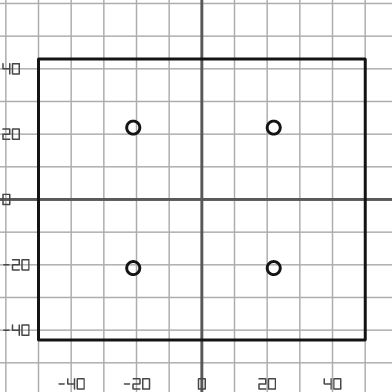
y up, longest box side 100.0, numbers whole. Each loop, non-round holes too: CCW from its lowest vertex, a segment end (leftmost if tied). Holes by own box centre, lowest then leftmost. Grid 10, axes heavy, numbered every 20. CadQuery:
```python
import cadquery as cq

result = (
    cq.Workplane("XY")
    .moveTo(-50.0, -43.0)
    .lineTo(50.0, -43.0)
    .lineTo(50.0, 43.0)
    .lineTo(-50.0, 43.0)
    .close()
    .moveTo(-21.0, -21.0)
    .circle(2.0)
    .moveTo(22.0, -21.0)
    .circle(2.0)
    .moveTo(-21.0, 22.0)
    .circle(2.0)
    .moveTo(22.0, 22.0)
    .circle(2.0)
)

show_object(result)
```